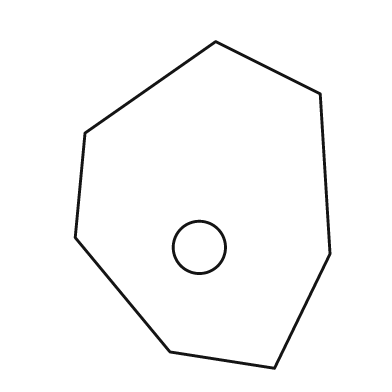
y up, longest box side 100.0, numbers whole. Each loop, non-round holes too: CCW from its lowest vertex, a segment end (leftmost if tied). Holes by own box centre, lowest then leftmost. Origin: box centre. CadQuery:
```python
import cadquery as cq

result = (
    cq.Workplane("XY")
    .moveTo(22.0, -50.0)
    .lineTo(39.0, -15.0)
    .lineTo(36.0, 34.0)
    .lineTo(4.0, 50.0)
    .lineTo(-36.0, 22.0)
    .lineTo(-39.0, -10.0)
    .lineTo(-10.0, -45.0)
    .close()
    .moveTo(-1.0, -13.0)
    .circle(8.0)
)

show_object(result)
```